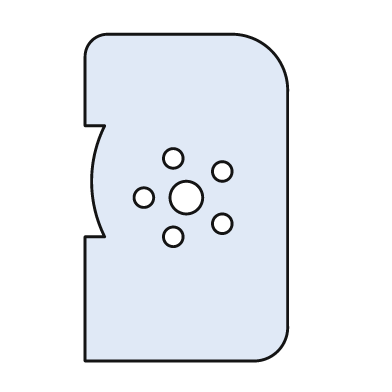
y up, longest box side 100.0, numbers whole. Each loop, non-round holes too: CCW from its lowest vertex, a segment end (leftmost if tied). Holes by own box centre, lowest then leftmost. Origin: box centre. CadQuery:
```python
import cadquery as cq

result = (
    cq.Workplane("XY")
    .moveTo(-31.0, -50.0)
    .lineTo(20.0, -50.0)
    .threePointArc((28.0, -47.0), (31.0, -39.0))
    .lineTo(31.0, 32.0)
    .threePointArc((26.0, 45.0), (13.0, 50.0))
    .lineTo(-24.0, 50.0)
    .threePointArc((-29.0, 48.0), (-31.0, 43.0))
    .lineTo(-31.0, 22.0)
    .lineTo(-25.0, 22.0)
    .threePointArc((-29.0, 5.0), (-25.0, -12.0))
    .lineTo(-31.0, -12.0)
    .close()
    .moveTo(-4.0, -12.0)
    .circle(3.0)
    .moveTo(11.0, -8.0)
    .circle(3.0)
    .moveTo(-13.0, 0.0)
    .circle(3.0)
    .moveTo(0.0, 0.0)
    .circle(5.0)
    .moveTo(11.0, 8.0)
    .circle(3.0)
    .moveTo(-4.0, 12.0)
    .circle(3.0)
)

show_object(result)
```